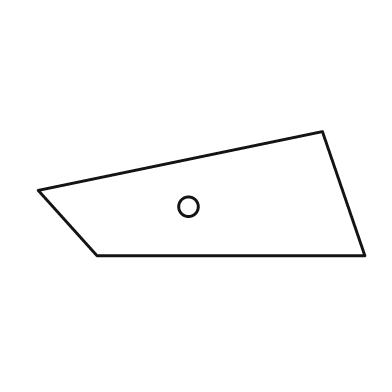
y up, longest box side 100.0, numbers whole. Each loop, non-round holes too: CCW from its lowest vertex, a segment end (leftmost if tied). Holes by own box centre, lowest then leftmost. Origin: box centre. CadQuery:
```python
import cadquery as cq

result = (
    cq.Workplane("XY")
    .moveTo(-32.0, -19.0)
    .lineTo(50.0, -19.0)
    .lineTo(37.0, 19.0)
    .lineTo(-50.0, 1.0)
    .close()
    .moveTo(-4.0, -4.0)
    .circle(3.0)
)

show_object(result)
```